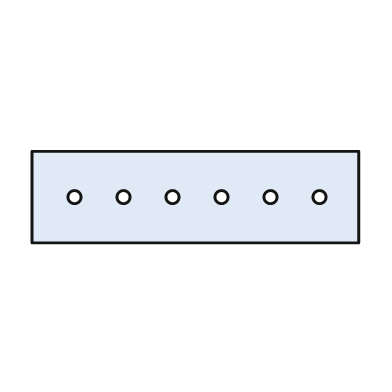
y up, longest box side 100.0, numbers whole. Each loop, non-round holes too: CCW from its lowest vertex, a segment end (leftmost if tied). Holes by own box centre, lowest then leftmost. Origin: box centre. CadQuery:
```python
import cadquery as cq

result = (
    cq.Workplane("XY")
    .moveTo(-50.0, -14.0)
    .lineTo(50.0, -14.0)
    .lineTo(50.0, 14.0)
    .lineTo(-50.0, 14.0)
    .close()
    .moveTo(-37.0, 0.0)
    .circle(2.0)
    .moveTo(-22.0, 0.0)
    .circle(2.0)
    .moveTo(-7.0, 0.0)
    .circle(2.0)
    .moveTo(8.0, 0.0)
    .circle(2.0)
    .moveTo(23.0, 0.0)
    .circle(2.0)
    .moveTo(38.0, 0.0)
    .circle(2.0)
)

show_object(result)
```